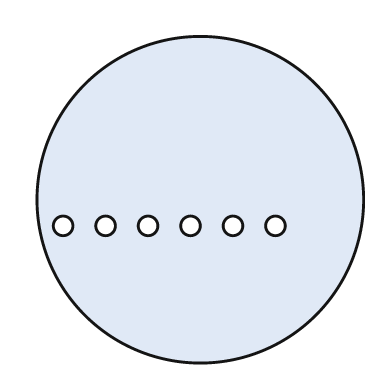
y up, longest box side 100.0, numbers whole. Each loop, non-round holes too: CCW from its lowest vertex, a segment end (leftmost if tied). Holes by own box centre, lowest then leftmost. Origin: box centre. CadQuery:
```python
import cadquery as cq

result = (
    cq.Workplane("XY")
    .moveTo(0.0, 0.0)
    .circle(50.0)
    .moveTo(-42.0, -8.0)
    .circle(3.0)
    .moveTo(-29.0, -8.0)
    .circle(3.0)
    .moveTo(-16.0, -8.0)
    .circle(3.0)
    .moveTo(-3.0, -8.0)
    .circle(3.0)
    .moveTo(10.0, -8.0)
    .circle(3.0)
    .moveTo(23.0, -8.0)
    .circle(3.0)
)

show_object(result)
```